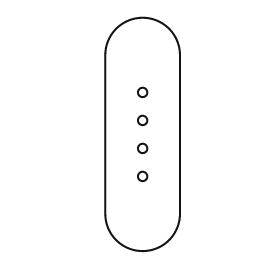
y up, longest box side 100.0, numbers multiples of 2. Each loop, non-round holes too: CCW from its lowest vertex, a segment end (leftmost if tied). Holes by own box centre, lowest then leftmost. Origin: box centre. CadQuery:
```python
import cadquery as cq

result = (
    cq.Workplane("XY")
    .moveTo(-16.0, -34.0)
    .threePointArc((0.0, -50.0), (16.0, -34.0))
    .lineTo(16.0, 34.0)
    .threePointArc((0.0, 50.0), (-16.0, 34.0))
    .close()
    .moveTo(0.0, -18.0)
    .circle(2.0)
    .moveTo(0.0, -6.0)
    .circle(2.0)
    .moveTo(0.0, 6.0)
    .circle(2.0)
    .moveTo(0.0, 18.0)
    .circle(2.0)
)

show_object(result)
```